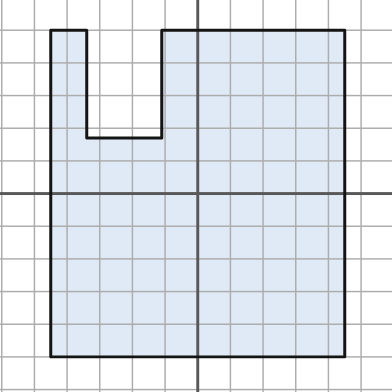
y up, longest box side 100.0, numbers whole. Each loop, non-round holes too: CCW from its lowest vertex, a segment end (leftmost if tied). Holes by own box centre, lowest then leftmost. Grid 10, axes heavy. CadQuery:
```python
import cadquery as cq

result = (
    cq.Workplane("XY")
    .moveTo(-45.0, -50.0)
    .lineTo(45.0, -50.0)
    .lineTo(45.0, 50.0)
    .lineTo(-11.0, 50.0)
    .lineTo(-11.0, 17.0)
    .lineTo(-34.0, 17.0)
    .lineTo(-34.0, 50.0)
    .lineTo(-45.0, 50.0)
    .close()
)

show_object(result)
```